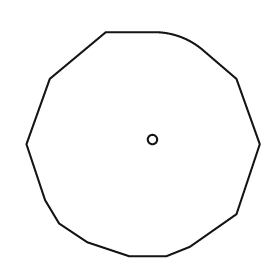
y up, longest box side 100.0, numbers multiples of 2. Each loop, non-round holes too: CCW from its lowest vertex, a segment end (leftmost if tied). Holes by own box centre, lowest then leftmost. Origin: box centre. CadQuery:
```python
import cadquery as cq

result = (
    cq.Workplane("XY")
    .moveTo(-6.0, -48.0)
    .lineTo(10.0, -48.0)
    .lineTo(20.0, -44.0)
    .lineTo(40.0, -30.0)
    .lineTo(50.0, 0.0)
    .lineTo(40.0, 28.0)
    .lineTo(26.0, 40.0)
    .threePointArc((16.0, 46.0), (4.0, 48.0))
    .lineTo(-16.0, 48.0)
    .lineTo(-40.0, 28.0)
    .lineTo(-50.0, 0.0)
    .lineTo(-42.0, -24.0)
    .lineTo(-36.0, -34.0)
    .lineTo(-24.0, -42.0)
    .close()
    .moveTo(4.0, 2.0)
    .circle(2.0)
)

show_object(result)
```